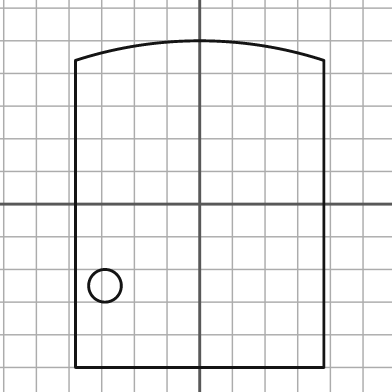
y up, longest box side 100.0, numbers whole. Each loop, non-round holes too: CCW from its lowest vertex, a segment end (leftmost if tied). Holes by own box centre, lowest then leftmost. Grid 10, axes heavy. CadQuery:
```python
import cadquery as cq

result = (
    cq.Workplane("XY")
    .moveTo(-38.0, -50.0)
    .lineTo(38.0, -50.0)
    .lineTo(38.0, 44.0)
    .threePointArc((0.0, 50.0), (-38.0, 44.0))
    .close()
    .moveTo(-29.0, -25.0)
    .circle(5.0)
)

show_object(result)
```